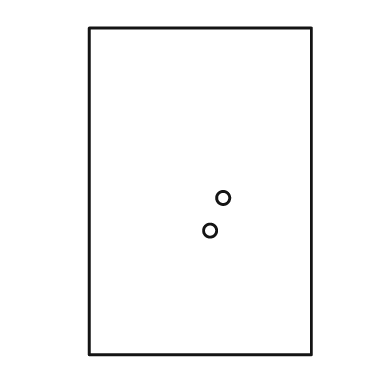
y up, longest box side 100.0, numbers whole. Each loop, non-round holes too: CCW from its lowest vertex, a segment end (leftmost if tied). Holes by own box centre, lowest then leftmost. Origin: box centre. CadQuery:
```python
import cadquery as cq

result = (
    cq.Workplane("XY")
    .moveTo(-34.0, -50.0)
    .lineTo(34.0, -50.0)
    .lineTo(34.0, 50.0)
    .lineTo(-34.0, 50.0)
    .close()
    .moveTo(3.0, -12.0)
    .circle(2.0)
    .moveTo(7.0, -2.0)
    .circle(2.0)
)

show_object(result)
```